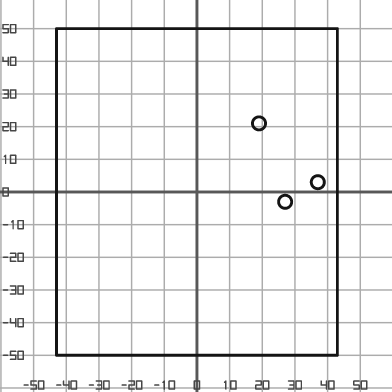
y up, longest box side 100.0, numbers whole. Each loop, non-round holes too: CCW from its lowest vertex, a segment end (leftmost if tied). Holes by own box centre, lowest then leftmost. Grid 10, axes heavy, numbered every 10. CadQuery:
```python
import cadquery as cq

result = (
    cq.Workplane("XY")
    .moveTo(-43.0, -50.0)
    .lineTo(43.0, -50.0)
    .lineTo(43.0, 50.0)
    .lineTo(-43.0, 50.0)
    .close()
    .moveTo(27.0, -3.0)
    .circle(2.0)
    .moveTo(37.0, 3.0)
    .circle(2.0)
    .moveTo(19.0, 21.0)
    .circle(2.0)
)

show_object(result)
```